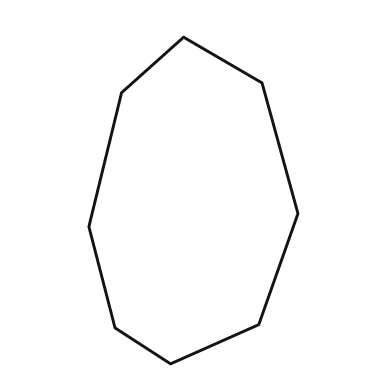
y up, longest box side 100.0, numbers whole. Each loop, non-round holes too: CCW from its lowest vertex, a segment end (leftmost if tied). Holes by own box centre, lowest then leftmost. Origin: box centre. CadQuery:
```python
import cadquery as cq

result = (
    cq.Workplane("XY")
    .moveTo(-7.0, -50.0)
    .lineTo(20.0, -38.0)
    .lineTo(32.0, -4.0)
    .lineTo(21.0, 36.0)
    .lineTo(-3.0, 50.0)
    .lineTo(-22.0, 33.0)
    .lineTo(-32.0, -8.0)
    .lineTo(-24.0, -39.0)
    .close()
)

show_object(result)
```